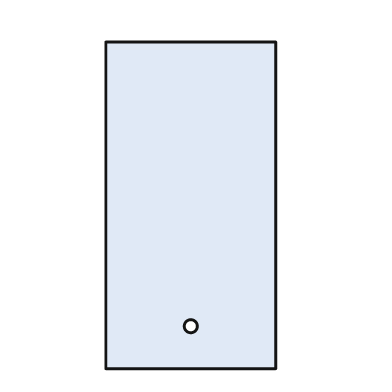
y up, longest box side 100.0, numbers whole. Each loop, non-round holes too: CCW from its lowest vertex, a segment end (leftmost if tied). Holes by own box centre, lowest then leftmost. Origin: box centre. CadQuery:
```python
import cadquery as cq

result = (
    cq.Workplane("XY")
    .moveTo(-26.0, -50.0)
    .lineTo(26.0, -50.0)
    .lineTo(26.0, 50.0)
    .lineTo(-26.0, 50.0)
    .close()
    .moveTo(0.0, -37.0)
    .circle(2.0)
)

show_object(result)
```